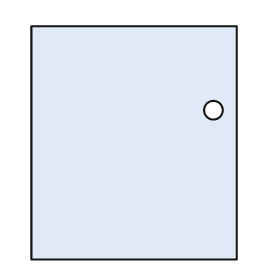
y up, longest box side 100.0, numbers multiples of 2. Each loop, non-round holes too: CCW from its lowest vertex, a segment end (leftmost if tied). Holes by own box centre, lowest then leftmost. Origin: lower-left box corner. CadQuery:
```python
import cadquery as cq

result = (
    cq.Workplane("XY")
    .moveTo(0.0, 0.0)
    .lineTo(88.0, 0.0)
    .lineTo(88.0, 100.0)
    .lineTo(0.0, 100.0)
    .close()
    .moveTo(78.0, 64.0)
    .circle(4.0)
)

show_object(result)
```